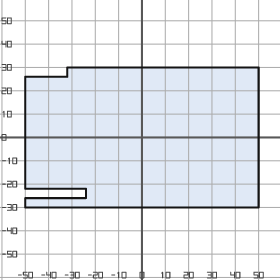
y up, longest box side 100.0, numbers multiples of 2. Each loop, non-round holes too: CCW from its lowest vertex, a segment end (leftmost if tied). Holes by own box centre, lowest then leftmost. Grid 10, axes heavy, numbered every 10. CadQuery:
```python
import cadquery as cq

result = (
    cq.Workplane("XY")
    .moveTo(-50.0, -30.0)
    .lineTo(50.0, -30.0)
    .lineTo(50.0, 30.0)
    .lineTo(-32.0, 30.0)
    .lineTo(-32.0, 26.0)
    .lineTo(-50.0, 26.0)
    .lineTo(-50.0, -22.0)
    .lineTo(-24.0, -22.0)
    .lineTo(-24.0, -26.0)
    .lineTo(-50.0, -26.0)
    .close()
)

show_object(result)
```